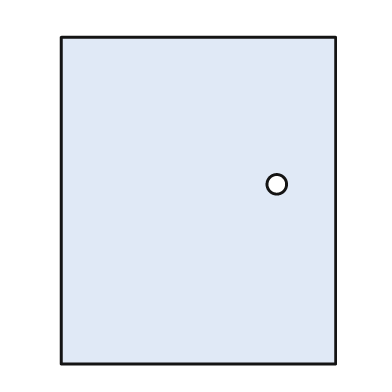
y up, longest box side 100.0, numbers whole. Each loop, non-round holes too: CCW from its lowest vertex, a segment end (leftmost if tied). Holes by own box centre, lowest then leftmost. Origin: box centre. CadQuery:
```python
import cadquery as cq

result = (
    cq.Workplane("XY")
    .moveTo(-42.0, -50.0)
    .lineTo(42.0, -50.0)
    .lineTo(42.0, 50.0)
    .lineTo(-42.0, 50.0)
    .close()
    .moveTo(24.0, 5.0)
    .circle(3.0)
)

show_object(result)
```